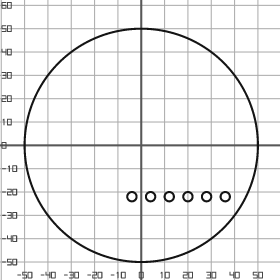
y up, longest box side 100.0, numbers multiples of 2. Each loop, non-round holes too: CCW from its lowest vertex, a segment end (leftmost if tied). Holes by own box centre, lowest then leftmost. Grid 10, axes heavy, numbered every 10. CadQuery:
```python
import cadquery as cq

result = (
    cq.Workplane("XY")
    .moveTo(0.0, 0.0)
    .circle(50.0)
    .moveTo(-4.0, -22.0)
    .circle(2.0)
    .moveTo(4.0, -22.0)
    .circle(2.0)
    .moveTo(12.0, -22.0)
    .circle(2.0)
    .moveTo(20.0, -22.0)
    .circle(2.0)
    .moveTo(28.0, -22.0)
    .circle(2.0)
    .moveTo(36.0, -22.0)
    .circle(2.0)
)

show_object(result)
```